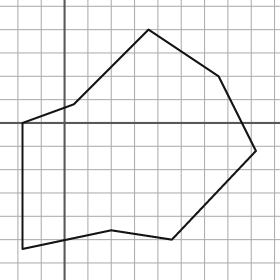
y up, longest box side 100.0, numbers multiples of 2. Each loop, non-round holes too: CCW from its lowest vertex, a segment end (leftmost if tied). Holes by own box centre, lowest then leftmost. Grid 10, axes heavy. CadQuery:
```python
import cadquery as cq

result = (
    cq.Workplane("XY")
    .moveTo(-18.0, -54.0)
    .lineTo(20.0, -46.0)
    .lineTo(46.0, -50.0)
    .lineTo(82.0, -12.0)
    .lineTo(66.0, 20.0)
    .lineTo(36.0, 40.0)
    .lineTo(4.0, 8.0)
    .lineTo(-18.0, 0.0)
    .close()
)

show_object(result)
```